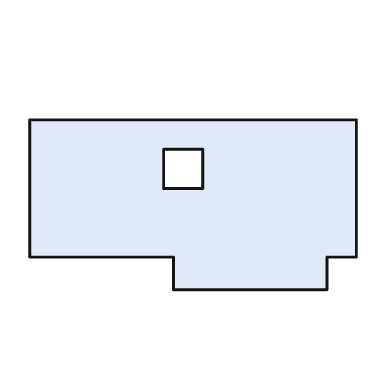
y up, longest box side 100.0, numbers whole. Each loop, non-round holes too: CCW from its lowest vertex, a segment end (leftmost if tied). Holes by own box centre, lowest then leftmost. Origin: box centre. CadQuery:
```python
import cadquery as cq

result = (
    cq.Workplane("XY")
    .moveTo(-6.0, -26.0)
    .lineTo(41.0, -26.0)
    .lineTo(41.0, -16.0)
    .lineTo(50.0, -16.0)
    .lineTo(50.0, 26.0)
    .lineTo(-50.0, 26.0)
    .lineTo(-50.0, -16.0)
    .lineTo(-6.0, -16.0)
    .close()
    .moveTo(-9.0, 5.0)
    .lineTo(3.0, 5.0)
    .lineTo(3.0, 17.0)
    .lineTo(-9.0, 17.0)
    .close()
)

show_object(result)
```